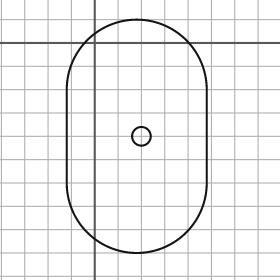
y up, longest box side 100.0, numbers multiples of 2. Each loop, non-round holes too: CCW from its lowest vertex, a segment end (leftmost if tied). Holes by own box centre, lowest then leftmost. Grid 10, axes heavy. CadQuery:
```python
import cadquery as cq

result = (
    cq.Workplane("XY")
    .moveTo(-12.0, -60.0)
    .threePointArc((18.0, -90.0), (48.0, -60.0))
    .lineTo(48.0, -20.0)
    .threePointArc((18.0, 10.0), (-12.0, -20.0))
    .close()
    .moveTo(20.0, -40.0)
    .circle(4.0)
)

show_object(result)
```